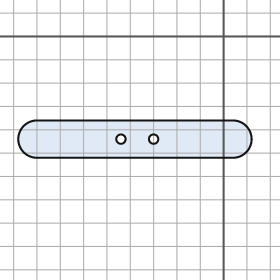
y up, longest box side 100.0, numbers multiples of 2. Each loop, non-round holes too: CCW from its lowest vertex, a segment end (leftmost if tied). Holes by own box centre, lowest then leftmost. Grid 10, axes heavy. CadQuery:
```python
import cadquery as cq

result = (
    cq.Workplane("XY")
    .moveTo(-80.0, -52.0)
    .lineTo(4.0, -52.0)
    .threePointArc((12.0, -44.0), (4.0, -36.0))
    .lineTo(-80.0, -36.0)
    .threePointArc((-88.0, -44.0), (-80.0, -52.0))
    .close()
    .moveTo(-44.0, -44.0)
    .circle(2.0)
    .moveTo(-30.0, -44.0)
    .circle(2.0)
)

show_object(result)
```